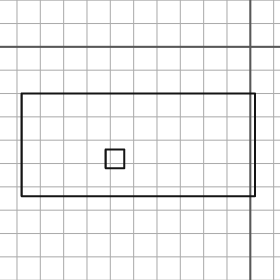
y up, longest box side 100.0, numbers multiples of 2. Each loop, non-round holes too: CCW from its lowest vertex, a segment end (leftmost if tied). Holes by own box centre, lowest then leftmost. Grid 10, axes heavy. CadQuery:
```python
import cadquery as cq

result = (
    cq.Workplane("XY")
    .moveTo(-98.0, -64.0)
    .lineTo(2.0, -64.0)
    .lineTo(2.0, -20.0)
    .lineTo(-98.0, -20.0)
    .close()
    .moveTo(-62.0, -52.0)
    .lineTo(-54.0, -52.0)
    .lineTo(-54.0, -44.0)
    .lineTo(-62.0, -44.0)
    .close()
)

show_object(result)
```